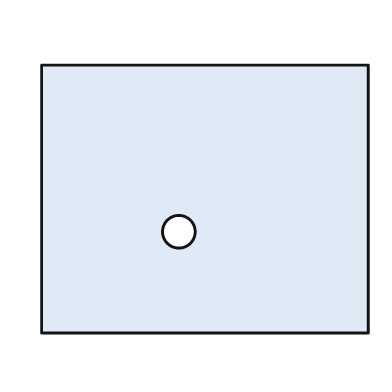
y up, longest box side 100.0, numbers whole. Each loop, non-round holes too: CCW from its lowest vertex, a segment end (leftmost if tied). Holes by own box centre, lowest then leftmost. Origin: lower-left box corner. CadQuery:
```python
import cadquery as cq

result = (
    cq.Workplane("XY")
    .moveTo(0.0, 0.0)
    .lineTo(100.0, 0.0)
    .lineTo(100.0, 82.0)
    .lineTo(0.0, 82.0)
    .close()
    .moveTo(42.0, 31.0)
    .circle(5.0)
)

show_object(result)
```